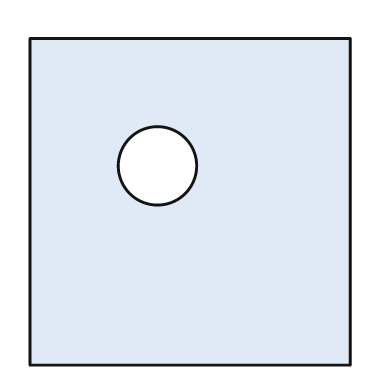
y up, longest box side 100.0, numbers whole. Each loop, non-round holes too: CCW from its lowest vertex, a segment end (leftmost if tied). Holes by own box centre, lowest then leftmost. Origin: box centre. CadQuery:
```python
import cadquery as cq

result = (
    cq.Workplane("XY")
    .moveTo(-49.0, -50.0)
    .lineTo(49.0, -50.0)
    .lineTo(49.0, 50.0)
    .lineTo(-49.0, 50.0)
    .close()
    .moveTo(-10.0, 11.0)
    .circle(12.0)
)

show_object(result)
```